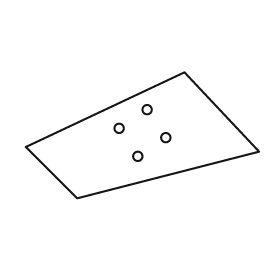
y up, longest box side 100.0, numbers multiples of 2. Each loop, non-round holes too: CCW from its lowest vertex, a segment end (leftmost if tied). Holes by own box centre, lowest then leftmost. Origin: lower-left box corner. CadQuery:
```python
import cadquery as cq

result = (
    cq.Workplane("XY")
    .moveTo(22.0, 0.0)
    .lineTo(100.0, 20.0)
    .lineTo(68.0, 54.0)
    .lineTo(0.0, 22.0)
    .close()
    .moveTo(48.0, 18.0)
    .circle(2.0)
    .moveTo(60.0, 26.0)
    .circle(2.0)
    .moveTo(40.0, 30.0)
    .circle(2.0)
    .moveTo(52.0, 38.0)
    .circle(2.0)
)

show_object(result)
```